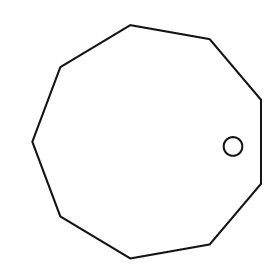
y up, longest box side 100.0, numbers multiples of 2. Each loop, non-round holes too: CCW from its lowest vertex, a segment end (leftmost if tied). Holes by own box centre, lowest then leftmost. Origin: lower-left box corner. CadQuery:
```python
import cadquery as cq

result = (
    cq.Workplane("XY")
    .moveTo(42.0, 0.0)
    .lineTo(76.0, 6.0)
    .lineTo(98.0, 32.0)
    .lineTo(98.0, 68.0)
    .lineTo(76.0, 94.0)
    .lineTo(42.0, 100.0)
    .lineTo(12.0, 82.0)
    .lineTo(0.0, 50.0)
    .lineTo(12.0, 18.0)
    .close()
    .moveTo(86.0, 48.0)
    .circle(4.0)
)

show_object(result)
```